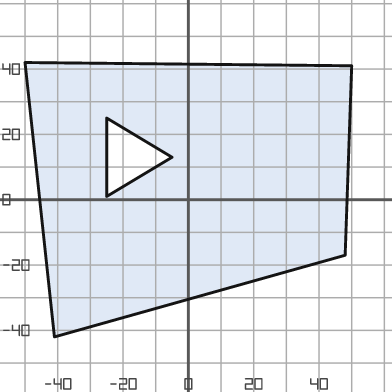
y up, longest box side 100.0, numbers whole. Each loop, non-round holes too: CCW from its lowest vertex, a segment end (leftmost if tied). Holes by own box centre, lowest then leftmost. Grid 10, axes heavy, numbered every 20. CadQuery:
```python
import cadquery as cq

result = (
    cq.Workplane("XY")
    .moveTo(-41.0, -42.0)
    .lineTo(48.0, -17.0)
    .lineTo(50.0, 41.0)
    .lineTo(-50.0, 42.0)
    .close()
    .moveTo(-25.0, 1.0)
    .lineTo(-5.0, 13.0)
    .lineTo(-25.0, 25.0)
    .close()
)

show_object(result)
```